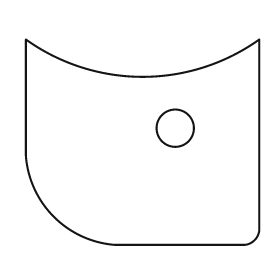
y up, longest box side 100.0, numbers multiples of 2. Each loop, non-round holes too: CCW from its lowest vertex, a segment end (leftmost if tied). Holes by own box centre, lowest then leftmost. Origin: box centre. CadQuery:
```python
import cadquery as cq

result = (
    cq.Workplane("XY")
    .moveTo(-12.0, -44.0)
    .lineTo(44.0, -44.0)
    .threePointArc((48.0, -42.0), (50.0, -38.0))
    .lineTo(50.0, 44.0)
    .threePointArc((0.0, 28.0), (-50.0, 44.0))
    .lineTo(-50.0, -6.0)
    .threePointArc((-38.0, -32.0), (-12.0, -44.0))
    .close()
    .moveTo(14.0, 6.0)
    .circle(8.0)
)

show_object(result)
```